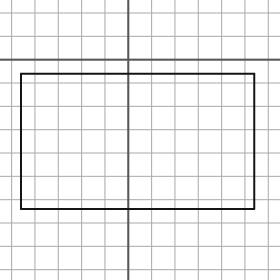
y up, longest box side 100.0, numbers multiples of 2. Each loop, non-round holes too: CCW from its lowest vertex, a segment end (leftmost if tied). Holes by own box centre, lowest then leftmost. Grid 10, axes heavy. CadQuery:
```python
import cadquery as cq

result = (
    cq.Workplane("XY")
    .moveTo(-46.0, -64.0)
    .lineTo(54.0, -64.0)
    .lineTo(54.0, -6.0)
    .lineTo(-46.0, -6.0)
    .close()
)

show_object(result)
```